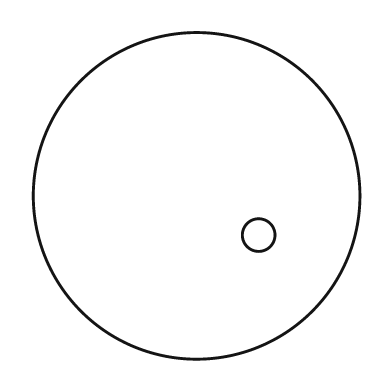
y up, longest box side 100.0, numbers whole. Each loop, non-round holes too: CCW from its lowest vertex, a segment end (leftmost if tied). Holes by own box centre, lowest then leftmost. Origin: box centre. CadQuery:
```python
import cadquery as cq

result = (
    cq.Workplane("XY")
    .moveTo(0.0, 0.0)
    .circle(50.0)
    .moveTo(19.0, -12.0)
    .circle(5.0)
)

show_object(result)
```